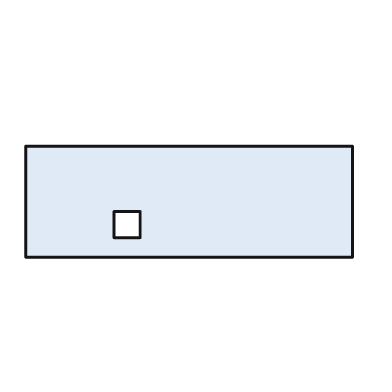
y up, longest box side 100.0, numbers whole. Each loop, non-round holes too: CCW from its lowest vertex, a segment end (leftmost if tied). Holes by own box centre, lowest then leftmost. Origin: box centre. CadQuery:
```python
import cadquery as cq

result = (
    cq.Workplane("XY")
    .moveTo(-50.0, -17.0)
    .lineTo(50.0, -17.0)
    .lineTo(50.0, 17.0)
    .lineTo(-50.0, 17.0)
    .close()
    .moveTo(-23.0, -11.0)
    .lineTo(-15.0, -11.0)
    .lineTo(-15.0, -3.0)
    .lineTo(-23.0, -3.0)
    .close()
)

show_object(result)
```